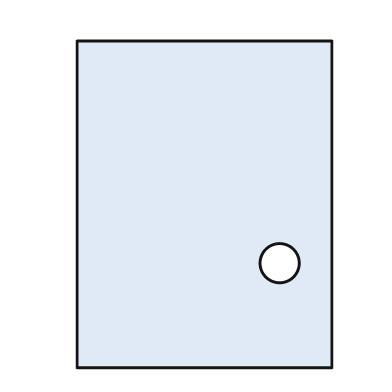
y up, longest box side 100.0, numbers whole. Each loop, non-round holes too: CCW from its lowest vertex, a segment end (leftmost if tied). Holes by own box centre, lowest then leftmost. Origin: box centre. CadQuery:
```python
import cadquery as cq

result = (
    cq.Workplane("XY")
    .moveTo(-39.0, -50.0)
    .lineTo(39.0, -50.0)
    .lineTo(39.0, 50.0)
    .lineTo(-39.0, 50.0)
    .close()
    .moveTo(23.0, -18.0)
    .circle(6.0)
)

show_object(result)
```